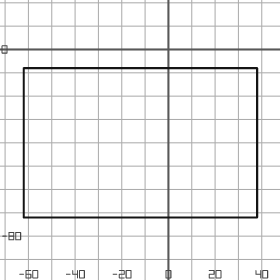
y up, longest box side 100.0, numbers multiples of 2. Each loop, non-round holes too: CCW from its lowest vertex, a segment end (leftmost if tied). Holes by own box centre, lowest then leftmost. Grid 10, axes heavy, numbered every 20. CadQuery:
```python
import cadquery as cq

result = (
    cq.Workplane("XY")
    .moveTo(-62.0, -72.0)
    .lineTo(38.0, -72.0)
    .lineTo(38.0, -8.0)
    .lineTo(-62.0, -8.0)
    .close()
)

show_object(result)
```